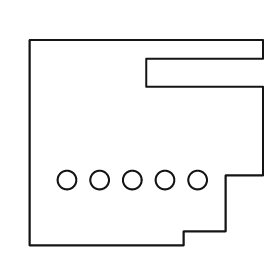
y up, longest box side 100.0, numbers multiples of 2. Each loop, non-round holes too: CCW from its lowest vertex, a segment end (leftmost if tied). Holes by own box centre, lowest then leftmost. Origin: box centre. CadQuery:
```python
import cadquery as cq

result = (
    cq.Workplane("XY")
    .moveTo(-50.0, -44.0)
    .lineTo(16.0, -44.0)
    .lineTo(16.0, -38.0)
    .lineTo(34.0, -38.0)
    .lineTo(34.0, -14.0)
    .lineTo(50.0, -14.0)
    .lineTo(50.0, 24.0)
    .lineTo(0.0, 24.0)
    .lineTo(0.0, 36.0)
    .lineTo(50.0, 36.0)
    .lineTo(50.0, 44.0)
    .lineTo(-50.0, 44.0)
    .close()
    .moveTo(-34.0, -16.0)
    .circle(4.0)
    .moveTo(-20.0, -16.0)
    .circle(4.0)
    .moveTo(-6.0, -16.0)
    .circle(4.0)
    .moveTo(8.0, -16.0)
    .circle(4.0)
    .moveTo(22.0, -16.0)
    .circle(4.0)
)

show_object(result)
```